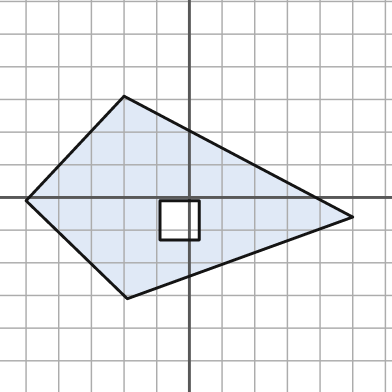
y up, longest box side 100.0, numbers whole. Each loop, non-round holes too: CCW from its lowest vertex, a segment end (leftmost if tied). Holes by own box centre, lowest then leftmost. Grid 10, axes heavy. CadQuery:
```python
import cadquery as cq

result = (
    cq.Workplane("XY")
    .moveTo(-19.0, -31.0)
    .lineTo(50.0, -6.0)
    .lineTo(-20.0, 31.0)
    .lineTo(-50.0, -1.0)
    .close()
    .moveTo(-9.0, -13.0)
    .lineTo(3.0, -13.0)
    .lineTo(3.0, -1.0)
    .lineTo(-9.0, -1.0)
    .close()
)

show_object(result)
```